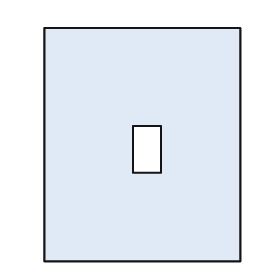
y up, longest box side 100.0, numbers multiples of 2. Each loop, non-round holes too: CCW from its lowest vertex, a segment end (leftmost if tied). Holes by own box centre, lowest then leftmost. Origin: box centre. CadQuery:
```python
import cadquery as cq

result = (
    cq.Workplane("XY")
    .moveTo(-42.0, -50.0)
    .lineTo(42.0, -50.0)
    .lineTo(42.0, 50.0)
    .lineTo(-42.0, 50.0)
    .close()
    .moveTo(-4.0, -12.0)
    .lineTo(8.0, -12.0)
    .lineTo(8.0, 8.0)
    .lineTo(-4.0, 8.0)
    .close()
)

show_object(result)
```